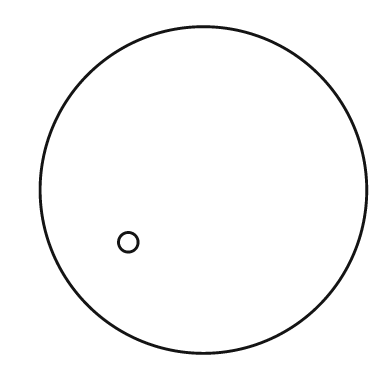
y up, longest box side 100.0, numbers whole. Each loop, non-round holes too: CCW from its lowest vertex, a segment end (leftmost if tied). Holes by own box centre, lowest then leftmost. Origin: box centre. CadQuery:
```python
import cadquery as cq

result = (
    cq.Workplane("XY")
    .moveTo(0.0, 0.0)
    .circle(50.0)
    .moveTo(-23.0, -16.0)
    .circle(3.0)
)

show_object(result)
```